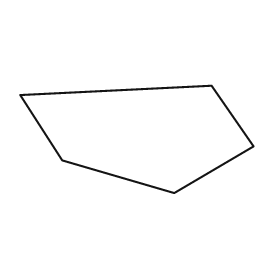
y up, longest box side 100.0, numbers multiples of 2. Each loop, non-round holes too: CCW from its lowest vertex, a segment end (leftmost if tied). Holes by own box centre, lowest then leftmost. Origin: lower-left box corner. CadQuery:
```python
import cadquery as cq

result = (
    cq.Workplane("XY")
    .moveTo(66.0, 0.0)
    .lineTo(100.0, 20.0)
    .lineTo(82.0, 46.0)
    .lineTo(0.0, 42.0)
    .lineTo(18.0, 14.0)
    .close()
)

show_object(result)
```